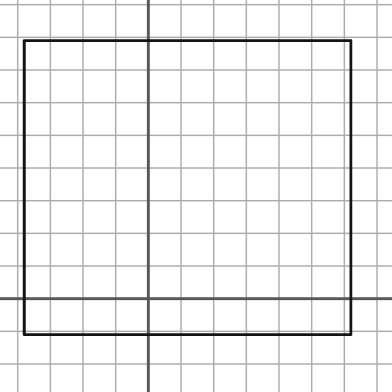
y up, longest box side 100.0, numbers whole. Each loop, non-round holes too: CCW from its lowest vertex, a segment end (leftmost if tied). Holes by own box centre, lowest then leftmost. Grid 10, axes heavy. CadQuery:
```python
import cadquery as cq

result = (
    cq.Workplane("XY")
    .moveTo(-38.0, -11.0)
    .lineTo(62.0, -11.0)
    .lineTo(62.0, 79.0)
    .lineTo(-38.0, 79.0)
    .close()
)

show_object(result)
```